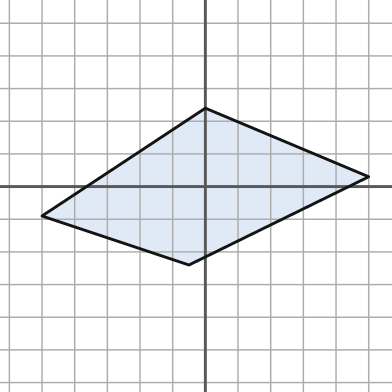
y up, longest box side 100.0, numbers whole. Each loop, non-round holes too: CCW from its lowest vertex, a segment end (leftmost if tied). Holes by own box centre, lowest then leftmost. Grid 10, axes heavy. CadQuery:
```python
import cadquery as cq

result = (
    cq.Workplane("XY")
    .moveTo(-5.0, -24.0)
    .lineTo(50.0, 3.0)
    .lineTo(0.0, 24.0)
    .lineTo(-50.0, -9.0)
    .close()
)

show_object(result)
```